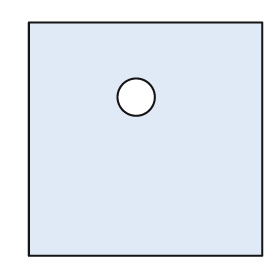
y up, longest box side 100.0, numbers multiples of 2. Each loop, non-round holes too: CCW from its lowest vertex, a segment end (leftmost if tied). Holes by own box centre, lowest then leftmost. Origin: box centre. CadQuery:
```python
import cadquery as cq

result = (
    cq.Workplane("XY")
    .moveTo(-50.0, -50.0)
    .lineTo(50.0, -50.0)
    .lineTo(50.0, 50.0)
    .lineTo(-50.0, 50.0)
    .close()
    .moveTo(-4.0, 18.0)
    .circle(8.0)
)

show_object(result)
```